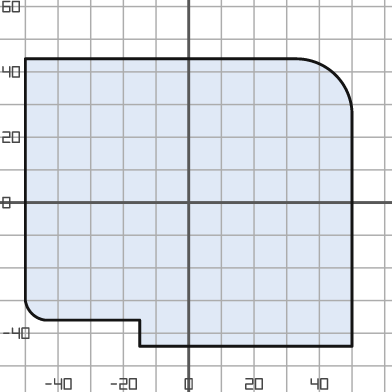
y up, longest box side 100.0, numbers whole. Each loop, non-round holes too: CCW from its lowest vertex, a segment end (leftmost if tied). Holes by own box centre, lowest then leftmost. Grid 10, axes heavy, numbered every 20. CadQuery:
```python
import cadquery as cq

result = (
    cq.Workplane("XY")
    .moveTo(-15.0, -44.0)
    .lineTo(50.0, -44.0)
    .lineTo(50.0, 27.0)
    .threePointArc((45.0, 39.0), (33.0, 44.0))
    .lineTo(-50.0, 44.0)
    .lineTo(-50.0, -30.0)
    .threePointArc((-48.0, -34.0), (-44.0, -36.0))
    .lineTo(-15.0, -36.0)
    .close()
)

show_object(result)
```